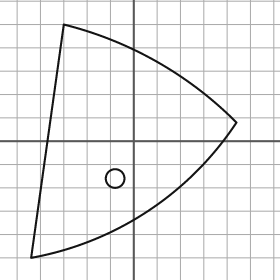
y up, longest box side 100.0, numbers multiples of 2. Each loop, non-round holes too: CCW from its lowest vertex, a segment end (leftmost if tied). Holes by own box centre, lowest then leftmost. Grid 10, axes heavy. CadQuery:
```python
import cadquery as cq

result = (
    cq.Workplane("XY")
    .moveTo(-44.0, -50.0)
    .threePointArc((6.0, -30.0), (44.0, 8.0))
    .threePointArc((10.0, 34.0), (-30.0, 50.0))
    .close()
    .moveTo(-8.0, -16.0)
    .circle(4.0)
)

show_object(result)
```